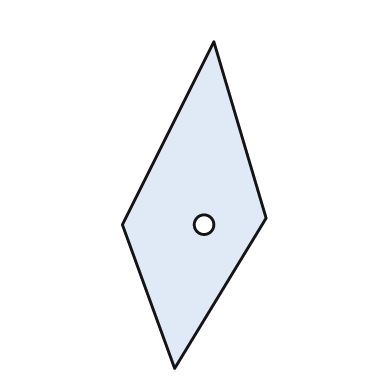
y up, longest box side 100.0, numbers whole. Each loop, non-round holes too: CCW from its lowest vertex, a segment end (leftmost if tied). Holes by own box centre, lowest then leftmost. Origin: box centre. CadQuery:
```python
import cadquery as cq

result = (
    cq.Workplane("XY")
    .moveTo(-6.0, -50.0)
    .lineTo(22.0, -4.0)
    .lineTo(6.0, 50.0)
    .lineTo(-22.0, -6.0)
    .close()
    .moveTo(3.0, -6.0)
    .circle(3.0)
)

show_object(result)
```